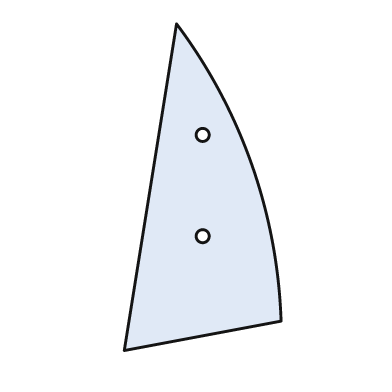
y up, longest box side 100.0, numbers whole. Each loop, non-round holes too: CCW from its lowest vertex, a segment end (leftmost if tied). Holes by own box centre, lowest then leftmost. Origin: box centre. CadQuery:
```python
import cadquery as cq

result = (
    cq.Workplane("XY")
    .moveTo(-24.0, -50.0)
    .lineTo(24.0, -41.0)
    .threePointArc((15.0, 7.0), (-8.0, 50.0))
    .close()
    .moveTo(0.0, -15.0)
    .circle(2.0)
    .moveTo(0.0, 16.0)
    .circle(2.0)
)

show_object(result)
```